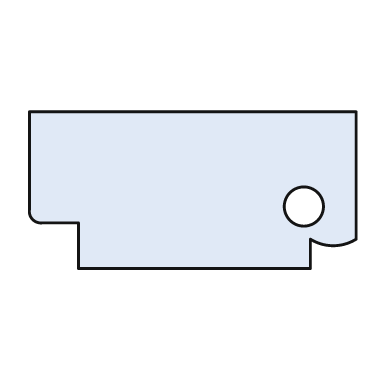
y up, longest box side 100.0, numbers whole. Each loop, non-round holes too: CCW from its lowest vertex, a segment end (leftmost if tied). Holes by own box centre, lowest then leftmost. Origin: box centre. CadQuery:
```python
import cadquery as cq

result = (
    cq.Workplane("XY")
    .moveTo(-35.0, -24.0)
    .lineTo(36.0, -24.0)
    .lineTo(36.0, -15.0)
    .threePointArc((43.0, -17.0), (50.0, -15.0))
    .lineTo(50.0, 24.0)
    .lineTo(-50.0, 24.0)
    .lineTo(-50.0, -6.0)
    .threePointArc((-49.0, -9.0), (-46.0, -10.0))
    .lineTo(-35.0, -10.0)
    .close()
    .moveTo(34.0, -5.0)
    .circle(6.0)
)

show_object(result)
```